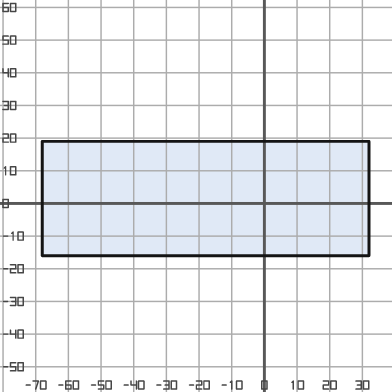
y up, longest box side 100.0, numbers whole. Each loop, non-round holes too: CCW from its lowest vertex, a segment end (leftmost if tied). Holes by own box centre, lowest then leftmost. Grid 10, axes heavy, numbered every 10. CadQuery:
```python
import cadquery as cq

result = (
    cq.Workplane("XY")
    .moveTo(-68.0, -16.0)
    .lineTo(32.0, -16.0)
    .lineTo(32.0, 19.0)
    .lineTo(-68.0, 19.0)
    .close()
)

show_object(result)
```